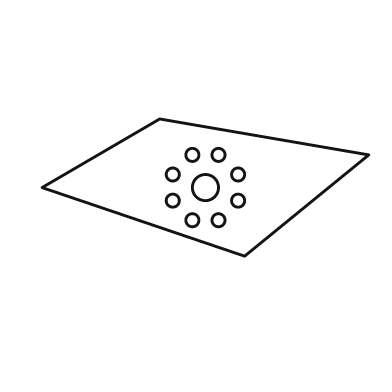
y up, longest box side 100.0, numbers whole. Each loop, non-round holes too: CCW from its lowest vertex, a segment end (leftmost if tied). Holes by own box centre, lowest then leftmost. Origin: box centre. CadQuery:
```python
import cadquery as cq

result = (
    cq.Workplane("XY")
    .moveTo(12.0, -21.0)
    .lineTo(50.0, 10.0)
    .lineTo(-14.0, 21.0)
    .lineTo(-50.0, 0.0)
    .close()
    .moveTo(-4.0, -10.0)
    .circle(2.0)
    .moveTo(4.0, -10.0)
    .circle(2.0)
    .moveTo(-10.0, -4.0)
    .circle(2.0)
    .moveTo(10.0, -4.0)
    .circle(2.0)
    .moveTo(0.0, 0.0)
    .circle(4.0)
    .moveTo(-10.0, 4.0)
    .circle(2.0)
    .moveTo(10.0, 4.0)
    .circle(2.0)
    .moveTo(-4.0, 10.0)
    .circle(2.0)
    .moveTo(4.0, 10.0)
    .circle(2.0)
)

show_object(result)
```